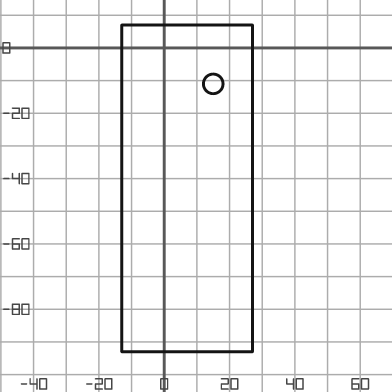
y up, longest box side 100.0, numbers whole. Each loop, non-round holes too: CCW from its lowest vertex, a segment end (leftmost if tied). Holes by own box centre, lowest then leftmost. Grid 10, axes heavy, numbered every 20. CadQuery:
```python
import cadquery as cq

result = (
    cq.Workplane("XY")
    .moveTo(-13.0, -93.0)
    .lineTo(27.0, -93.0)
    .lineTo(27.0, 7.0)
    .lineTo(-13.0, 7.0)
    .close()
    .moveTo(15.0, -11.0)
    .circle(3.0)
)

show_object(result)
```